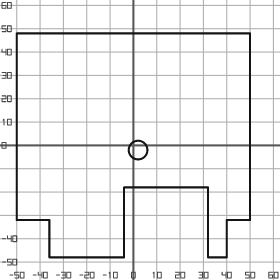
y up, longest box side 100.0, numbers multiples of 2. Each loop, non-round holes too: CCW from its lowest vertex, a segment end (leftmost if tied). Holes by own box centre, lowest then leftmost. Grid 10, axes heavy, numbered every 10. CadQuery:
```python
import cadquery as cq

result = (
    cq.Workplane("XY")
    .moveTo(-36.0, -48.0)
    .lineTo(-4.0, -48.0)
    .lineTo(-4.0, -18.0)
    .lineTo(32.0, -18.0)
    .lineTo(32.0, -48.0)
    .lineTo(40.0, -48.0)
    .lineTo(40.0, -32.0)
    .lineTo(50.0, -32.0)
    .lineTo(50.0, 48.0)
    .lineTo(-50.0, 48.0)
    .lineTo(-50.0, -32.0)
    .lineTo(-36.0, -32.0)
    .close()
    .moveTo(2.0, -2.0)
    .circle(4.0)
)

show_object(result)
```